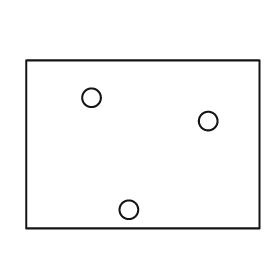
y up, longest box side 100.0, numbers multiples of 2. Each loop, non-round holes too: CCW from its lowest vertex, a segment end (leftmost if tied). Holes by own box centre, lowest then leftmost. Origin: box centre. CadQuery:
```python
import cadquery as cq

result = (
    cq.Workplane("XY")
    .moveTo(-50.0, -36.0)
    .lineTo(50.0, -36.0)
    .lineTo(50.0, 36.0)
    .lineTo(-50.0, 36.0)
    .close()
    .moveTo(-6.0, -28.0)
    .circle(4.0)
    .moveTo(28.0, 10.0)
    .circle(4.0)
    .moveTo(-22.0, 20.0)
    .circle(4.0)
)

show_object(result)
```